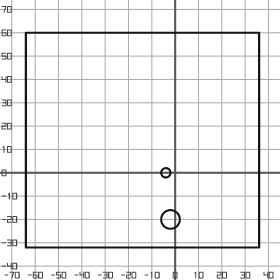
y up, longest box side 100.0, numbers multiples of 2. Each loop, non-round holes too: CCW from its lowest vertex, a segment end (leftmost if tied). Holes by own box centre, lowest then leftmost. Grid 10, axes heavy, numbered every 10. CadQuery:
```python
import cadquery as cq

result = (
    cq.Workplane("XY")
    .moveTo(-64.0, -32.0)
    .lineTo(36.0, -32.0)
    .lineTo(36.0, 60.0)
    .lineTo(-64.0, 60.0)
    .close()
    .moveTo(-2.0, -20.0)
    .circle(4.0)
    .moveTo(-4.0, 0.0)
    .circle(2.0)
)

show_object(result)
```